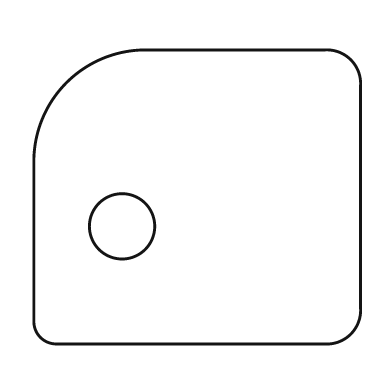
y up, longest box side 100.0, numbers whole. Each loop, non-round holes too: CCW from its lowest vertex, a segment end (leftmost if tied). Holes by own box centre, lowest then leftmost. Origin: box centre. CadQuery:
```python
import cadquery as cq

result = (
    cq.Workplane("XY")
    .moveTo(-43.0, -45.0)
    .lineTo(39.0, -45.0)
    .threePointArc((47.0, -42.0), (50.0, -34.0))
    .lineTo(50.0, 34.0)
    .threePointArc((47.0, 42.0), (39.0, 45.0))
    .lineTo(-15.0, 45.0)
    .threePointArc((-40.0, 35.0), (-50.0, 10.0))
    .lineTo(-50.0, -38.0)
    .threePointArc((-48.0, -43.0), (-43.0, -45.0))
    .close()
    .moveTo(-23.0, -9.0)
    .circle(10.0)
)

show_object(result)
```